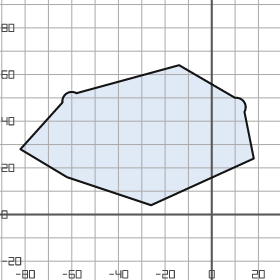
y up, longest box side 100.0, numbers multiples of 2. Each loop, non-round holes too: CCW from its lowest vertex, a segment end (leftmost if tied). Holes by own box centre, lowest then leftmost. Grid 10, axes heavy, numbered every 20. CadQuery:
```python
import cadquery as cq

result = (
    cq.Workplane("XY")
    .moveTo(-26.0, 4.0)
    .lineTo(18.0, 24.0)
    .lineTo(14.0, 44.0)
    .threePointArc((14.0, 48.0), (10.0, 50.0))
    .lineTo(-14.0, 64.0)
    .lineTo(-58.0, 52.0)
    .threePointArc((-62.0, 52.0), (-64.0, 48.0))
    .lineTo(-82.0, 28.0)
    .lineTo(-62.0, 16.0)
    .close()
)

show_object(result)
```